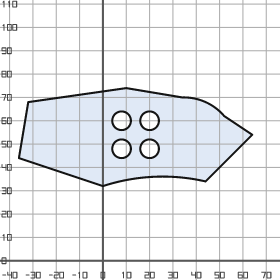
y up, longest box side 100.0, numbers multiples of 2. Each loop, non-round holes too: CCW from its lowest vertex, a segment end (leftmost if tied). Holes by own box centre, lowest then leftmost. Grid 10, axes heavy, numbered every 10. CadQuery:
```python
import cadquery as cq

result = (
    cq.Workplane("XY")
    .moveTo(0.0, 32.0)
    .threePointArc((22.0, 36.0), (44.0, 34.0))
    .lineTo(64.0, 54.0)
    .lineTo(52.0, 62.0)
    .threePointArc((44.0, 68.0), (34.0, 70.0))
    .lineTo(10.0, 74.0)
    .lineTo(-32.0, 68.0)
    .lineTo(-36.0, 44.0)
    .close()
    .moveTo(8.0, 48.0)
    .circle(4.0)
    .moveTo(20.0, 48.0)
    .circle(4.0)
    .moveTo(8.0, 60.0)
    .circle(4.0)
    .moveTo(20.0, 60.0)
    .circle(4.0)
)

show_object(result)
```